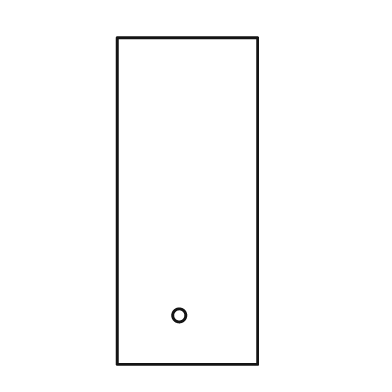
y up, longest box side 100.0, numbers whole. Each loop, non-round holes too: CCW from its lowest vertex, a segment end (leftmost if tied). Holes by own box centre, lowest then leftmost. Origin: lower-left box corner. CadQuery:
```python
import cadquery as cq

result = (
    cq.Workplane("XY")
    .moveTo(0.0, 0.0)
    .lineTo(43.0, 0.0)
    .lineTo(43.0, 100.0)
    .lineTo(0.0, 100.0)
    .close()
    .moveTo(19.0, 15.0)
    .circle(2.0)
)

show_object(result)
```